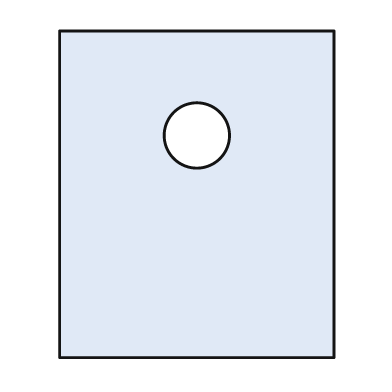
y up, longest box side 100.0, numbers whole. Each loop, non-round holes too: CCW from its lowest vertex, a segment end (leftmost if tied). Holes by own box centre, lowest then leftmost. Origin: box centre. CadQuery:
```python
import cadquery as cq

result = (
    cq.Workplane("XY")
    .moveTo(-42.0, -50.0)
    .lineTo(42.0, -50.0)
    .lineTo(42.0, 50.0)
    .lineTo(-42.0, 50.0)
    .close()
    .moveTo(0.0, 18.0)
    .circle(10.0)
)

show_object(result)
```